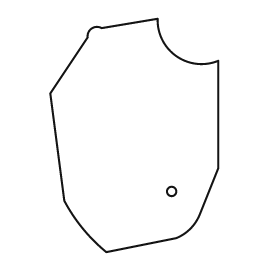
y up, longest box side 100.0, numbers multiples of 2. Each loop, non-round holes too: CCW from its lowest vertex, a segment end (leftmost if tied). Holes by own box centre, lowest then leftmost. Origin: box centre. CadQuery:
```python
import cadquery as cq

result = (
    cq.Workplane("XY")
    .moveTo(-12.0, -50.0)
    .lineTo(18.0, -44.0)
    .threePointArc((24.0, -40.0), (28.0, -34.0))
    .lineTo(36.0, -14.0)
    .lineTo(36.0, 32.0)
    .threePointArc((18.0, 34.0), (10.0, 50.0))
    .lineTo(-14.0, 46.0)
    .threePointArc((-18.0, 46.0), (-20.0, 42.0))
    .lineTo(-36.0, 18.0)
    .lineTo(-30.0, -28.0)
    .threePointArc((-22.0, -40.0), (-12.0, -50.0))
    .close()
    .moveTo(16.0, -24.0)
    .circle(2.0)
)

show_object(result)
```